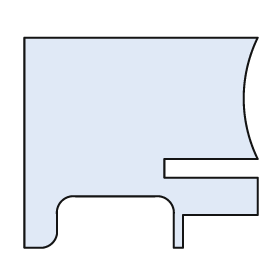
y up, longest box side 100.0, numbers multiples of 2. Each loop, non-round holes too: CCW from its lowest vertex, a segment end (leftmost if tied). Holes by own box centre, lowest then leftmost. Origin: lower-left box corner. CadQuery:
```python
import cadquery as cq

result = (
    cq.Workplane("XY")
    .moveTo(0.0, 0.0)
    .lineTo(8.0, 0.0)
    .threePointArc((12.0, 2.0), (14.0, 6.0))
    .lineTo(14.0, 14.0)
    .threePointArc((16.0, 20.0), (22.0, 22.0))
    .lineTo(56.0, 22.0)
    .threePointArc((62.0, 20.0), (64.0, 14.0))
    .lineTo(64.0, 0.0)
    .lineTo(68.0, 0.0)
    .lineTo(68.0, 14.0)
    .lineTo(100.0, 14.0)
    .lineTo(100.0, 30.0)
    .lineTo(60.0, 30.0)
    .lineTo(60.0, 38.0)
    .lineTo(100.0, 38.0)
    .threePointArc((94.0, 64.0), (100.0, 90.0))
    .lineTo(0.0, 90.0)
    .close()
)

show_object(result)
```